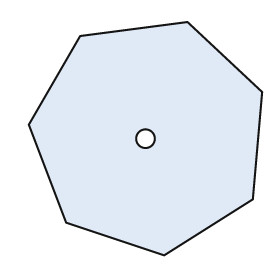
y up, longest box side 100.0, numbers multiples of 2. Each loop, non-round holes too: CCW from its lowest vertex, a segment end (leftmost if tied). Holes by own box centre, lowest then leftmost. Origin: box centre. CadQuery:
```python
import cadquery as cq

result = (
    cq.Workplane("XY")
    .moveTo(8.0, -50.0)
    .lineTo(46.0, -26.0)
    .lineTo(50.0, 20.0)
    .lineTo(18.0, 50.0)
    .lineTo(-28.0, 44.0)
    .lineTo(-50.0, 6.0)
    .lineTo(-34.0, -36.0)
    .close()
    .moveTo(0.0, 0.0)
    .circle(4.0)
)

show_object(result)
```